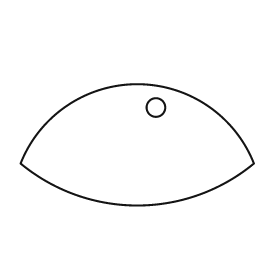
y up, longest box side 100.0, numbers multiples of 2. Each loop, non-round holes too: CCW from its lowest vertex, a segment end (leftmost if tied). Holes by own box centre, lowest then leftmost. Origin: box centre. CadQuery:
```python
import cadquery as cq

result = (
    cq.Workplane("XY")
    .moveTo(-50.0, -8.0)
    .threePointArc((0.0, -26.0), (50.0, -8.0))
    .threePointArc((0.0, 26.0), (-50.0, -8.0))
    .close()
    .moveTo(8.0, 16.0)
    .circle(4.0)
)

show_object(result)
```